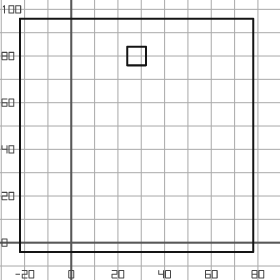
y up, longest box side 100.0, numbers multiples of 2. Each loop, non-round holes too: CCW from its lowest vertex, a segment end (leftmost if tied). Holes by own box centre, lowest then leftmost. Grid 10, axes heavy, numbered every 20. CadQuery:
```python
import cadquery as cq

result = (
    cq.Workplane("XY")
    .moveTo(-22.0, -4.0)
    .lineTo(78.0, -4.0)
    .lineTo(78.0, 96.0)
    .lineTo(-22.0, 96.0)
    .close()
    .moveTo(24.0, 76.0)
    .lineTo(32.0, 76.0)
    .lineTo(32.0, 84.0)
    .lineTo(24.0, 84.0)
    .close()
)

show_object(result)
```